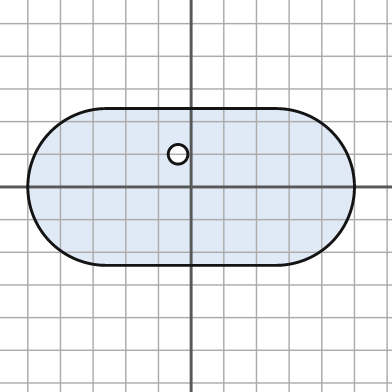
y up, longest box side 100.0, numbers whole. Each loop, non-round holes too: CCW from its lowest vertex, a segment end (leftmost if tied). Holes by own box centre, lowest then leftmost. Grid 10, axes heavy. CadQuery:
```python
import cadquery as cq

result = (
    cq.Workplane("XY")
    .moveTo(-26.0, -24.0)
    .lineTo(26.0, -24.0)
    .threePointArc((50.0, 0.0), (26.0, 24.0))
    .lineTo(-26.0, 24.0)
    .threePointArc((-50.0, 0.0), (-26.0, -24.0))
    .close()
    .moveTo(-4.0, 10.0)
    .circle(3.0)
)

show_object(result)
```